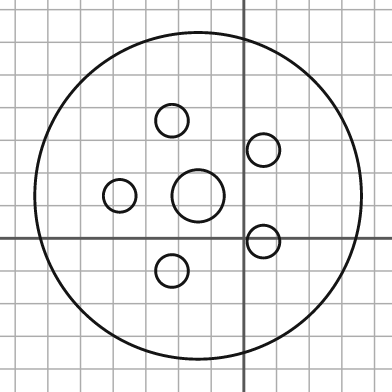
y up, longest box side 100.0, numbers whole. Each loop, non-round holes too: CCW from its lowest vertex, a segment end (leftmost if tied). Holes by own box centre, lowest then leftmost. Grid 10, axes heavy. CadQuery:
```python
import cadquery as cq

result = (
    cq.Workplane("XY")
    .moveTo(-14.0, 13.0)
    .circle(50.0)
    .moveTo(-22.0, -10.0)
    .circle(5.0)
    .moveTo(6.0, -1.0)
    .circle(5.0)
    .moveTo(-38.0, 13.0)
    .circle(5.0)
    .moveTo(-14.0, 13.0)
    .circle(8.0)
    .moveTo(6.0, 27.0)
    .circle(5.0)
    .moveTo(-22.0, 36.0)
    .circle(5.0)
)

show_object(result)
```